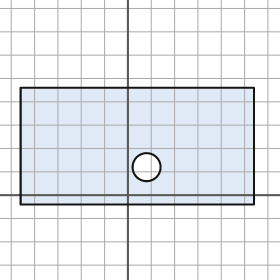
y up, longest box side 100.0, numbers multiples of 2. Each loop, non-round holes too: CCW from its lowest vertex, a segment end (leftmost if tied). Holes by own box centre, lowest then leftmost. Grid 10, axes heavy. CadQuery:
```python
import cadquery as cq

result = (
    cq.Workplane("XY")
    .moveTo(-46.0, -4.0)
    .lineTo(54.0, -4.0)
    .lineTo(54.0, 46.0)
    .lineTo(-46.0, 46.0)
    .close()
    .moveTo(8.0, 12.0)
    .circle(6.0)
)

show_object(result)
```